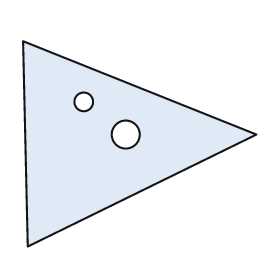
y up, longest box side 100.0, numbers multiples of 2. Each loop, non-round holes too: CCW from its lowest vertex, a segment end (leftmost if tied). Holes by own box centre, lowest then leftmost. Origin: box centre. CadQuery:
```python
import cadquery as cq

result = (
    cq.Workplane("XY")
    .moveTo(-48.0, -44.0)
    .lineTo(50.0, 4.0)
    .lineTo(-50.0, 44.0)
    .close()
    .moveTo(-6.0, 4.0)
    .circle(6.0)
    .moveTo(-24.0, 18.0)
    .circle(4.0)
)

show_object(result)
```